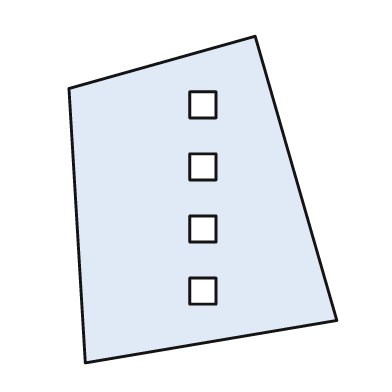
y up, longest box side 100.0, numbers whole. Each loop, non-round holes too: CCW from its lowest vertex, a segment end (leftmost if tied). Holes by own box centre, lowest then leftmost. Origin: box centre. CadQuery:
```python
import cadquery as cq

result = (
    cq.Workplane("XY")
    .moveTo(-36.0, -50.0)
    .lineTo(41.0, -37.0)
    .lineTo(16.0, 50.0)
    .lineTo(-41.0, 34.0)
    .close()
    .moveTo(-4.0, -32.0)
    .lineTo(4.0, -32.0)
    .lineTo(4.0, -24.0)
    .lineTo(-4.0, -24.0)
    .close()
    .moveTo(-4.0, -13.0)
    .lineTo(4.0, -13.0)
    .lineTo(4.0, -5.0)
    .lineTo(-4.0, -5.0)
    .close()
    .moveTo(-4.0, 6.0)
    .lineTo(4.0, 6.0)
    .lineTo(4.0, 14.0)
    .lineTo(-4.0, 14.0)
    .close()
    .moveTo(-4.0, 25.0)
    .lineTo(4.0, 25.0)
    .lineTo(4.0, 33.0)
    .lineTo(-4.0, 33.0)
    .close()
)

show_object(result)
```